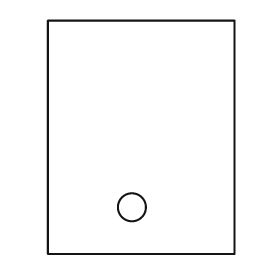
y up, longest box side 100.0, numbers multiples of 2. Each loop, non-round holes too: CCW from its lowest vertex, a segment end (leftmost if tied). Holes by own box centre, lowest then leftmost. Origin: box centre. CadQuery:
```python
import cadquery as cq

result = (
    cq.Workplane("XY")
    .moveTo(-40.0, -50.0)
    .lineTo(40.0, -50.0)
    .lineTo(40.0, 50.0)
    .lineTo(-40.0, 50.0)
    .close()
    .moveTo(-4.0, -30.0)
    .circle(6.0)
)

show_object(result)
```